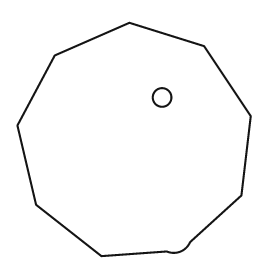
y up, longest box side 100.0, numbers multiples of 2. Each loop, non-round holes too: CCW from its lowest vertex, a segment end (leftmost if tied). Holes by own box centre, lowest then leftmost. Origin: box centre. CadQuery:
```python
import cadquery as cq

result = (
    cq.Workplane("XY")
    .moveTo(-14.0, -50.0)
    .lineTo(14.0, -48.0)
    .threePointArc((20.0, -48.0), (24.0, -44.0))
    .lineTo(46.0, -24.0)
    .lineTo(50.0, 10.0)
    .lineTo(30.0, 40.0)
    .lineTo(-2.0, 50.0)
    .lineTo(-34.0, 36.0)
    .lineTo(-50.0, 6.0)
    .lineTo(-42.0, -28.0)
    .close()
    .moveTo(12.0, 18.0)
    .circle(4.0)
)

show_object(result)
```